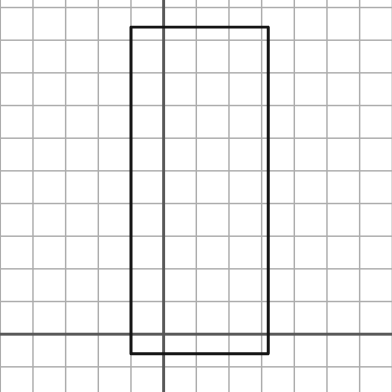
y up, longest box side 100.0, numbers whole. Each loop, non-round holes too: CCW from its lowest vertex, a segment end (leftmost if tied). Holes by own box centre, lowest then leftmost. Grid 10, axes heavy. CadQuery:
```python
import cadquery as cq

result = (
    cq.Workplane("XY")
    .moveTo(-10.0, -6.0)
    .lineTo(32.0, -6.0)
    .lineTo(32.0, 94.0)
    .lineTo(-10.0, 94.0)
    .close()
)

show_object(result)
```